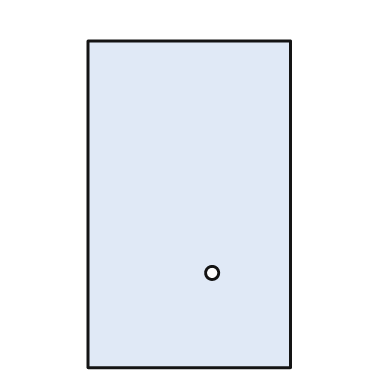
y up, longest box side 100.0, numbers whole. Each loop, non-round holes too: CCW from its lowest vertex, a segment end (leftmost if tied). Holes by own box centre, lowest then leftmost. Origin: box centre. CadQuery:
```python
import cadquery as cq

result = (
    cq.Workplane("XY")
    .moveTo(-31.0, -50.0)
    .lineTo(31.0, -50.0)
    .lineTo(31.0, 50.0)
    .lineTo(-31.0, 50.0)
    .close()
    .moveTo(7.0, -21.0)
    .circle(2.0)
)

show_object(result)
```